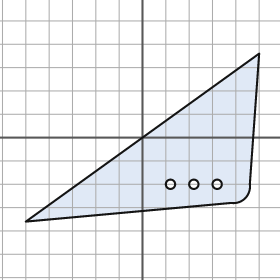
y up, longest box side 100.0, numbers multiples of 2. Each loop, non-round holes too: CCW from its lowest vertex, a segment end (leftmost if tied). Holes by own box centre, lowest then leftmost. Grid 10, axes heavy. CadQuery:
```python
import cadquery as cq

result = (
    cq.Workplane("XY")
    .moveTo(-50.0, -36.0)
    .lineTo(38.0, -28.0)
    .threePointArc((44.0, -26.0), (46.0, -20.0))
    .lineTo(50.0, 36.0)
    .close()
    .moveTo(12.0, -20.0)
    .circle(2.0)
    .moveTo(22.0, -20.0)
    .circle(2.0)
    .moveTo(32.0, -20.0)
    .circle(2.0)
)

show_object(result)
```